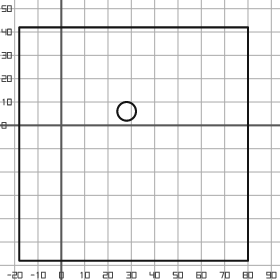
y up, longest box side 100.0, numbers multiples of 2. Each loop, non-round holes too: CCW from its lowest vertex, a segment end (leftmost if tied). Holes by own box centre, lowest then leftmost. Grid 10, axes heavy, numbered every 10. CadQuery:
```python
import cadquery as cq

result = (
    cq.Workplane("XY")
    .moveTo(-18.0, -58.0)
    .lineTo(80.0, -58.0)
    .lineTo(80.0, 42.0)
    .lineTo(-18.0, 42.0)
    .close()
    .moveTo(28.0, 6.0)
    .circle(4.0)
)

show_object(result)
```